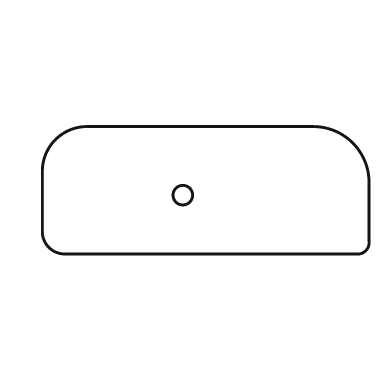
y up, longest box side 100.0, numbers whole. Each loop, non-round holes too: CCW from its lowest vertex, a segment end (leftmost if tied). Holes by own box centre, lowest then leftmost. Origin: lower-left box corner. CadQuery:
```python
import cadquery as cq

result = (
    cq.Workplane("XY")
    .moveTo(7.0, 0.0)
    .lineTo(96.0, 0.0)
    .threePointArc((99.0, 1.0), (100.0, 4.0))
    .lineTo(100.0, 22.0)
    .threePointArc((95.0, 34.0), (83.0, 39.0))
    .lineTo(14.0, 39.0)
    .threePointArc((4.0, 35.0), (0.0, 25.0))
    .lineTo(0.0, 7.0)
    .threePointArc((2.0, 2.0), (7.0, 0.0))
    .close()
    .moveTo(43.0, 18.0)
    .circle(3.0)
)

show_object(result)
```